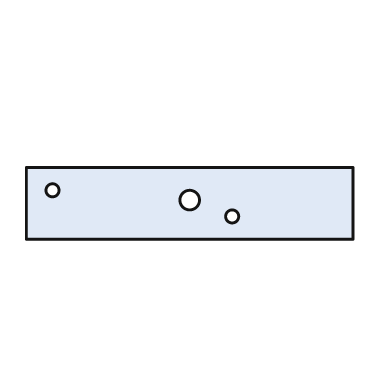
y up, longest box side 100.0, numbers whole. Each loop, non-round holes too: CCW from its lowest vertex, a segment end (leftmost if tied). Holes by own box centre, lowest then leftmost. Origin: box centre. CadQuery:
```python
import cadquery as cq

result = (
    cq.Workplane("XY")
    .moveTo(-50.0, -11.0)
    .lineTo(50.0, -11.0)
    .lineTo(50.0, 11.0)
    .lineTo(-50.0, 11.0)
    .close()
    .moveTo(13.0, -4.0)
    .circle(2.0)
    .moveTo(0.0, 1.0)
    .circle(3.0)
    .moveTo(-42.0, 4.0)
    .circle(2.0)
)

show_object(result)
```